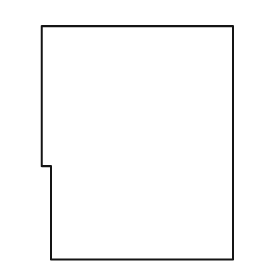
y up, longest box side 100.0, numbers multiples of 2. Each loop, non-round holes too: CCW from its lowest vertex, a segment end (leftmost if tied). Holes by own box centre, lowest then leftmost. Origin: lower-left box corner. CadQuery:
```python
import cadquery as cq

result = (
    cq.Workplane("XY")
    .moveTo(4.0, 0.0)
    .lineTo(82.0, 0.0)
    .lineTo(82.0, 100.0)
    .lineTo(0.0, 100.0)
    .lineTo(0.0, 40.0)
    .lineTo(4.0, 40.0)
    .close()
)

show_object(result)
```